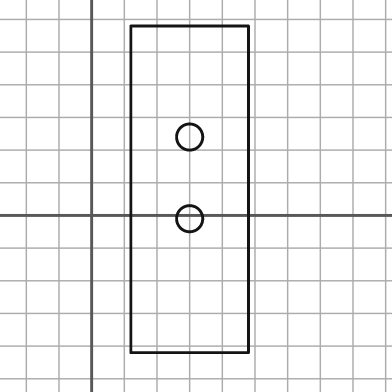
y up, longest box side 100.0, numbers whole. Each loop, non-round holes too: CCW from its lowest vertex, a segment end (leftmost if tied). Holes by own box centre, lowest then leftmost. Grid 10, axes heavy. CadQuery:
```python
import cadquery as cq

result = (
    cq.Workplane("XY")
    .moveTo(12.0, -42.0)
    .lineTo(48.0, -42.0)
    .lineTo(48.0, 58.0)
    .lineTo(12.0, 58.0)
    .close()
    .moveTo(30.0, -1.0)
    .circle(4.0)
    .moveTo(30.0, 24.0)
    .circle(4.0)
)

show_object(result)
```